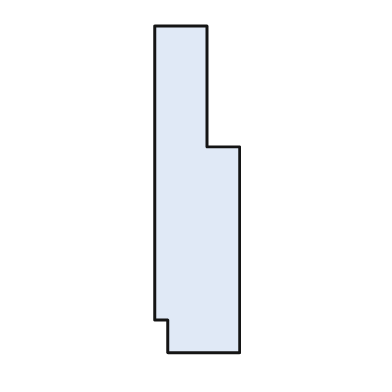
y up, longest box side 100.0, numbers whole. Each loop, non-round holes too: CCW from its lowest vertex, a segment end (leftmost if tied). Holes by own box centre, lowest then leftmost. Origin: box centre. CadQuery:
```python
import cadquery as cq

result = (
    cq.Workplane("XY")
    .moveTo(-9.0, -50.0)
    .lineTo(13.0, -50.0)
    .lineTo(13.0, 13.0)
    .lineTo(3.0, 13.0)
    .lineTo(3.0, 50.0)
    .lineTo(-13.0, 50.0)
    .lineTo(-13.0, -40.0)
    .lineTo(-9.0, -40.0)
    .close()
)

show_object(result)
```